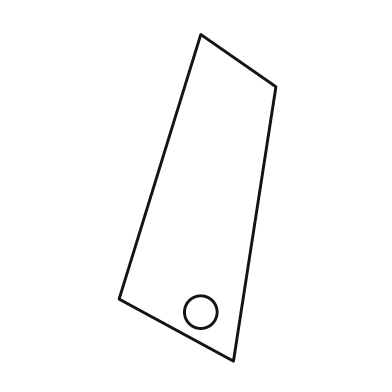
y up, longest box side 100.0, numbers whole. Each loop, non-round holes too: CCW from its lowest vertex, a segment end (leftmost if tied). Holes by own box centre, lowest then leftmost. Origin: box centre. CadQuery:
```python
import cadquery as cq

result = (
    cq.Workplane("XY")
    .moveTo(11.0, -50.0)
    .lineTo(24.0, 34.0)
    .lineTo(1.0, 50.0)
    .lineTo(-24.0, -31.0)
    .close()
    .moveTo(1.0, -35.0)
    .circle(5.0)
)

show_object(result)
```